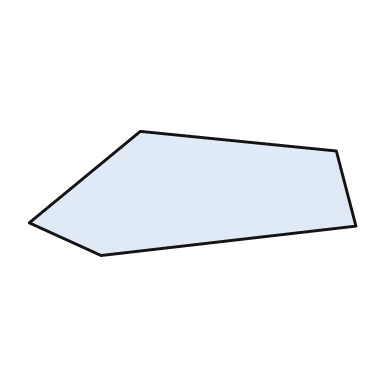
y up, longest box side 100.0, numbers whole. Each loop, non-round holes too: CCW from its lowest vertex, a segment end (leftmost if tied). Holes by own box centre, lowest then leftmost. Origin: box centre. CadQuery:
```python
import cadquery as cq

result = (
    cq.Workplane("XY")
    .moveTo(-28.0, -19.0)
    .lineTo(50.0, -10.0)
    .lineTo(44.0, 13.0)
    .lineTo(-16.0, 19.0)
    .lineTo(-50.0, -9.0)
    .close()
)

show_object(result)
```